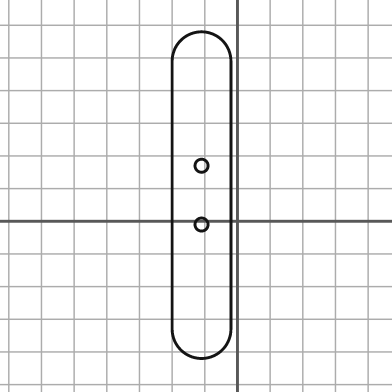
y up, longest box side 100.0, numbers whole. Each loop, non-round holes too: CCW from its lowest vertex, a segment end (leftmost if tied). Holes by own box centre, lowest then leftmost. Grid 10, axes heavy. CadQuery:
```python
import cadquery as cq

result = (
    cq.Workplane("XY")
    .moveTo(-20.0, -33.0)
    .threePointArc((-11.0, -42.0), (-2.0, -33.0))
    .lineTo(-2.0, 49.0)
    .threePointArc((-11.0, 58.0), (-20.0, 49.0))
    .close()
    .moveTo(-11.0, -1.0)
    .circle(2.0)
    .moveTo(-11.0, 17.0)
    .circle(2.0)
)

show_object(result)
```